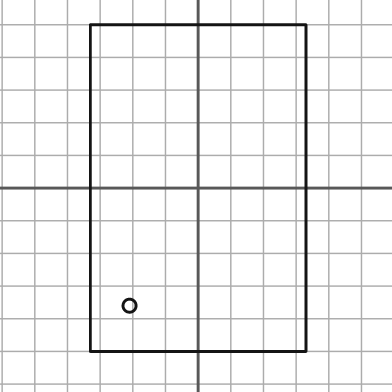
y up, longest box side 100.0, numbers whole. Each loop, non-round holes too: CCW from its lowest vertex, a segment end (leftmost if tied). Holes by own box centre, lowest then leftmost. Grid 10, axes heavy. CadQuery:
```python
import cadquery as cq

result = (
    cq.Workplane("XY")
    .moveTo(-33.0, -50.0)
    .lineTo(33.0, -50.0)
    .lineTo(33.0, 50.0)
    .lineTo(-33.0, 50.0)
    .close()
    .moveTo(-21.0, -36.0)
    .circle(2.0)
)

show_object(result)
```